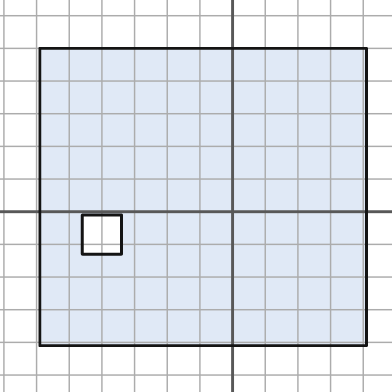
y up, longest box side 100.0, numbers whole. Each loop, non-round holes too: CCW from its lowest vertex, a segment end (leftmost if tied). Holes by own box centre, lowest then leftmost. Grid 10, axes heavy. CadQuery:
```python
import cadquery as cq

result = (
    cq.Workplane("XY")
    .moveTo(-59.0, -41.0)
    .lineTo(41.0, -41.0)
    .lineTo(41.0, 50.0)
    .lineTo(-59.0, 50.0)
    .close()
    .moveTo(-46.0, -13.0)
    .lineTo(-34.0, -13.0)
    .lineTo(-34.0, -1.0)
    .lineTo(-46.0, -1.0)
    .close()
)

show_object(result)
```